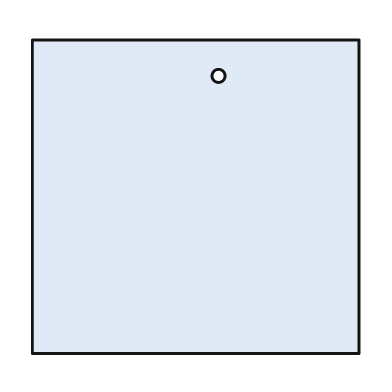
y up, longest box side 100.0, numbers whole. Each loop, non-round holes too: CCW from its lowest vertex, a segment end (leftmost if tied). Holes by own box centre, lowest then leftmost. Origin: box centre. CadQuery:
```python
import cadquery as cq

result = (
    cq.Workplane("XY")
    .moveTo(-50.0, -48.0)
    .lineTo(50.0, -48.0)
    .lineTo(50.0, 48.0)
    .lineTo(-50.0, 48.0)
    .close()
    .moveTo(7.0, 37.0)
    .circle(2.0)
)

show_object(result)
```